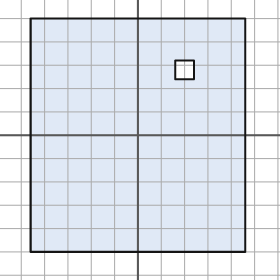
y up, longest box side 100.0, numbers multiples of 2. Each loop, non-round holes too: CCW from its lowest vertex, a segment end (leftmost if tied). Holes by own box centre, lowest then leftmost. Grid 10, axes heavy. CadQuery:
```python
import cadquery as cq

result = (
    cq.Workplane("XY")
    .moveTo(-46.0, -50.0)
    .lineTo(46.0, -50.0)
    .lineTo(46.0, 50.0)
    .lineTo(-46.0, 50.0)
    .close()
    .moveTo(16.0, 24.0)
    .lineTo(24.0, 24.0)
    .lineTo(24.0, 32.0)
    .lineTo(16.0, 32.0)
    .close()
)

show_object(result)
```